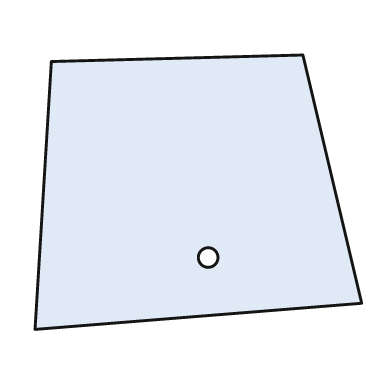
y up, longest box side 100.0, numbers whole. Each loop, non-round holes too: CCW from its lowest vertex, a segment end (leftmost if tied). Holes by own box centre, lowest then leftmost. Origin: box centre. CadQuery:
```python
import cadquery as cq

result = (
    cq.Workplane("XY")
    .moveTo(-50.0, -42.0)
    .lineTo(50.0, -34.0)
    .lineTo(32.0, 42.0)
    .lineTo(-45.0, 40.0)
    .close()
    .moveTo(3.0, -20.0)
    .circle(3.0)
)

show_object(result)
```